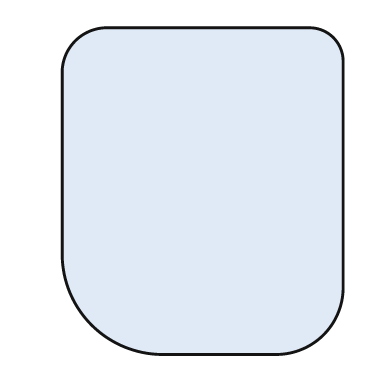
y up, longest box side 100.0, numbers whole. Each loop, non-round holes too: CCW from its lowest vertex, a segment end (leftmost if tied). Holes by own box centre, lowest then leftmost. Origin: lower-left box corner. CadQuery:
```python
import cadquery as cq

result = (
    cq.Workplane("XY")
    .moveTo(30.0, 0.0)
    .lineTo(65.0, 0.0)
    .threePointArc((80.0, 6.0), (86.0, 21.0))
    .lineTo(86.0, 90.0)
    .threePointArc((83.0, 97.0), (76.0, 100.0))
    .lineTo(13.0, 100.0)
    .threePointArc((4.0, 96.0), (0.0, 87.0))
    .lineTo(0.0, 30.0)
    .threePointArc((9.0, 9.0), (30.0, 0.0))
    .close()
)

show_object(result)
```